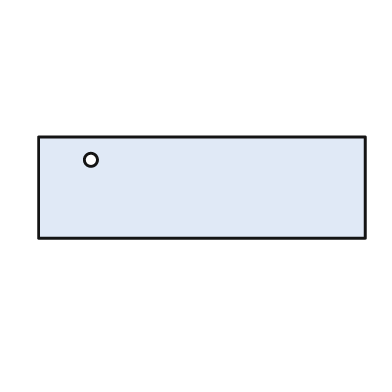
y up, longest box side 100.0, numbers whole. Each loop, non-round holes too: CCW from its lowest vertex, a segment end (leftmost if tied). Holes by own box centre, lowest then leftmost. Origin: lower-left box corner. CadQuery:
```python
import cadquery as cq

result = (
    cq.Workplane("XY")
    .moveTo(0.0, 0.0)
    .lineTo(100.0, 0.0)
    .lineTo(100.0, 31.0)
    .lineTo(0.0, 31.0)
    .close()
    .moveTo(16.0, 24.0)
    .circle(2.0)
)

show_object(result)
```